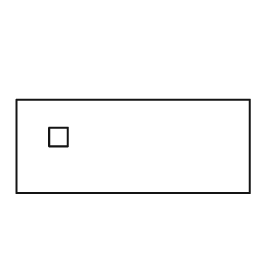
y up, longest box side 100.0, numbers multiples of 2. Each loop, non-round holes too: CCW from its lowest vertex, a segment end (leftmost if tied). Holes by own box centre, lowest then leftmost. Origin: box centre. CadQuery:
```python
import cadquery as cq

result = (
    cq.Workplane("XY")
    .moveTo(-50.0, -20.0)
    .lineTo(50.0, -20.0)
    .lineTo(50.0, 20.0)
    .lineTo(-50.0, 20.0)
    .close()
    .moveTo(-36.0, 0.0)
    .lineTo(-28.0, 0.0)
    .lineTo(-28.0, 8.0)
    .lineTo(-36.0, 8.0)
    .close()
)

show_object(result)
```